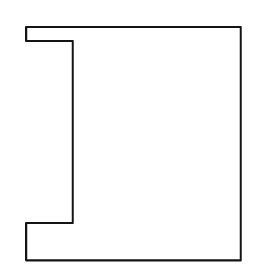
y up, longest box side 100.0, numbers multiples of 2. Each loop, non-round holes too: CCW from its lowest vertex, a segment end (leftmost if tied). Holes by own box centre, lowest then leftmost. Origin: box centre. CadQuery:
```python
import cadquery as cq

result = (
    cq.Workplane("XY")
    .moveTo(-46.0, -50.0)
    .lineTo(46.0, -50.0)
    .lineTo(46.0, 50.0)
    .lineTo(-46.0, 50.0)
    .lineTo(-46.0, 44.0)
    .lineTo(-26.0, 44.0)
    .lineTo(-26.0, -34.0)
    .lineTo(-46.0, -34.0)
    .close()
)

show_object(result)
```